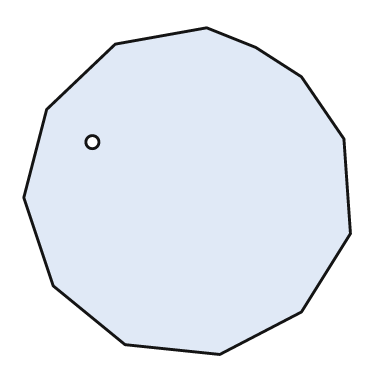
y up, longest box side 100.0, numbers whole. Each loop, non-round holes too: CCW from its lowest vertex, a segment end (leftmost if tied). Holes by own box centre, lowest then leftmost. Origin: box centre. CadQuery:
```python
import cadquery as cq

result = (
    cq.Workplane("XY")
    .moveTo(10.0, -50.0)
    .lineTo(35.0, -37.0)
    .lineTo(50.0, -13.0)
    .lineTo(48.0, 16.0)
    .lineTo(35.0, 35.0)
    .lineTo(21.0, 44.0)
    .lineTo(6.0, 50.0)
    .lineTo(-22.0, 45.0)
    .lineTo(-43.0, 25.0)
    .lineTo(-50.0, -2.0)
    .lineTo(-41.0, -29.0)
    .lineTo(-19.0, -47.0)
    .close()
    .moveTo(-29.0, 15.0)
    .circle(2.0)
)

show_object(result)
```